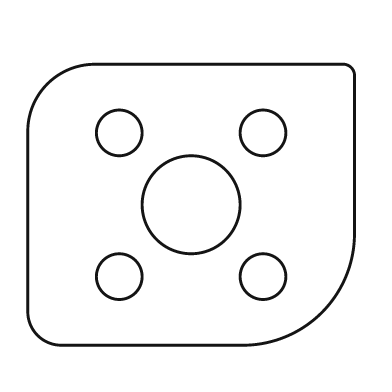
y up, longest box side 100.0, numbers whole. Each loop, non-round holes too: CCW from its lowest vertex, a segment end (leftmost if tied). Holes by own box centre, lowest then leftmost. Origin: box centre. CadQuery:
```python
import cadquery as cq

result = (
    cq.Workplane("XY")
    .moveTo(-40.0, -43.0)
    .lineTo(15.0, -43.0)
    .threePointArc((40.0, -33.0), (50.0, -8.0))
    .lineTo(50.0, 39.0)
    .threePointArc((49.0, 42.0), (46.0, 43.0))
    .lineTo(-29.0, 43.0)
    .threePointArc((-44.0, 37.0), (-50.0, 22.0))
    .lineTo(-50.0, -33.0)
    .threePointArc((-47.0, -40.0), (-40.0, -43.0))
    .close()
    .moveTo(-22.0, -22.0)
    .circle(7.0)
    .moveTo(22.0, -22.0)
    .circle(7.0)
    .moveTo(0.0, 0.0)
    .circle(15.0)
    .moveTo(-22.0, 22.0)
    .circle(7.0)
    .moveTo(22.0, 22.0)
    .circle(7.0)
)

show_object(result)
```